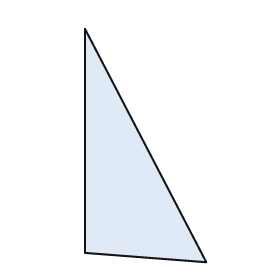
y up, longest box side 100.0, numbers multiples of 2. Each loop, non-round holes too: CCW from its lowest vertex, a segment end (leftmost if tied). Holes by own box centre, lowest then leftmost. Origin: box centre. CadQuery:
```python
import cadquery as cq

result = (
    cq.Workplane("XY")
    .moveTo(26.0, -50.0)
    .lineTo(-26.0, 50.0)
    .lineTo(-26.0, -46.0)
    .close()
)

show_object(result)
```